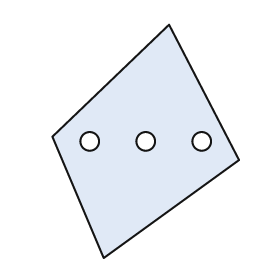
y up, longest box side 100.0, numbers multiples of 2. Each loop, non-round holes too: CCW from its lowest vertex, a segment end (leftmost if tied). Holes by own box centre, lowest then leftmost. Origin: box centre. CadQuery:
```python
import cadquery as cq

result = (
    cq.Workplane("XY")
    .moveTo(-18.0, -50.0)
    .lineTo(40.0, -8.0)
    .lineTo(10.0, 50.0)
    .lineTo(-40.0, 2.0)
    .close()
    .moveTo(-24.0, 0.0)
    .circle(4.0)
    .moveTo(0.0, 0.0)
    .circle(4.0)
    .moveTo(24.0, 0.0)
    .circle(4.0)
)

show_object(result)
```